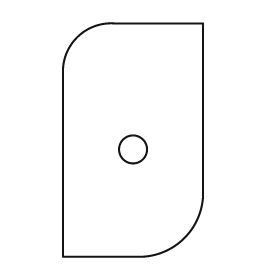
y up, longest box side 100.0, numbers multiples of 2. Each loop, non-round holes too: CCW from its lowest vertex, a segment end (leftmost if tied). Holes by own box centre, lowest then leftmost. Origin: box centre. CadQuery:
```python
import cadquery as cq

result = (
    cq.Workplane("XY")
    .moveTo(-30.0, -50.0)
    .lineTo(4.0, -50.0)
    .threePointArc((22.0, -42.0), (30.0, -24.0))
    .lineTo(30.0, 50.0)
    .lineTo(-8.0, 50.0)
    .threePointArc((-24.0, 44.0), (-30.0, 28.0))
    .close()
    .moveTo(0.0, -4.0)
    .circle(6.0)
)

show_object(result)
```